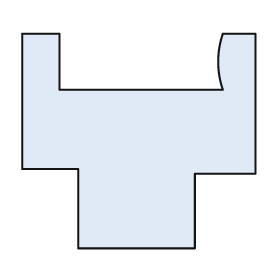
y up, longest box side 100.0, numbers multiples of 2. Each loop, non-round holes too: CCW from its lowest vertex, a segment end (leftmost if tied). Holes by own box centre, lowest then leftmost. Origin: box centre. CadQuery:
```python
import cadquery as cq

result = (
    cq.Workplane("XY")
    .moveTo(-26.0, -46.0)
    .lineTo(24.0, -46.0)
    .lineTo(24.0, -14.0)
    .lineTo(50.0, -14.0)
    .lineTo(50.0, 46.0)
    .lineTo(36.0, 46.0)
    .threePointArc((34.0, 34.0), (36.0, 22.0))
    .lineTo(-34.0, 22.0)
    .lineTo(-34.0, 46.0)
    .lineTo(-50.0, 46.0)
    .lineTo(-50.0, -12.0)
    .lineTo(-26.0, -12.0)
    .close()
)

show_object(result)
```